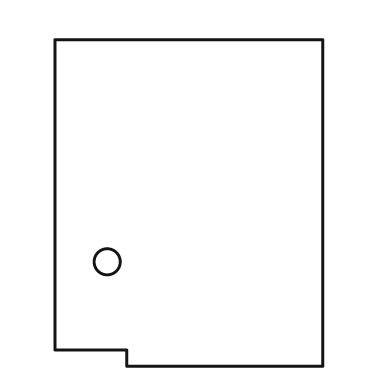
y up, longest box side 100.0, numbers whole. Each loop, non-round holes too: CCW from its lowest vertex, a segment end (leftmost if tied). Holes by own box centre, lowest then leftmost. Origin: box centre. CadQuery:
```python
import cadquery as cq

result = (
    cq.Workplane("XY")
    .moveTo(-19.0, -50.0)
    .lineTo(41.0, -50.0)
    .lineTo(41.0, 50.0)
    .lineTo(-41.0, 50.0)
    .lineTo(-41.0, -45.0)
    .lineTo(-19.0, -45.0)
    .close()
    .moveTo(-25.0, -18.0)
    .circle(4.0)
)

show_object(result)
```